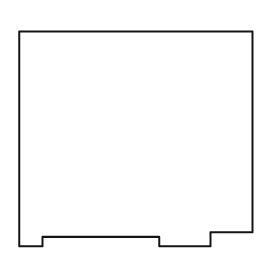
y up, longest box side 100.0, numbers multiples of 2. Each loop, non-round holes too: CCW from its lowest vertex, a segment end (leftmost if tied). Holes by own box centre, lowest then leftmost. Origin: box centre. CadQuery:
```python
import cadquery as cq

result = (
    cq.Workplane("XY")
    .moveTo(-50.0, -46.0)
    .lineTo(-40.0, -46.0)
    .lineTo(-40.0, -42.0)
    .lineTo(10.0, -42.0)
    .lineTo(10.0, -46.0)
    .lineTo(32.0, -46.0)
    .lineTo(32.0, -40.0)
    .lineTo(50.0, -40.0)
    .lineTo(50.0, 46.0)
    .lineTo(-50.0, 46.0)
    .close()
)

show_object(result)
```